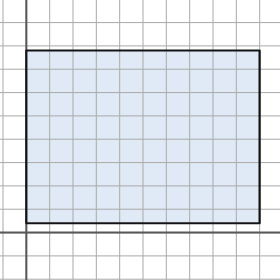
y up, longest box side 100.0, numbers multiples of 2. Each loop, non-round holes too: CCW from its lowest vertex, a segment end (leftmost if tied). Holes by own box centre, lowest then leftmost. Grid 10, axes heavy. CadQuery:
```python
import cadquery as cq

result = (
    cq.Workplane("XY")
    .moveTo(0.0, 4.0)
    .lineTo(100.0, 4.0)
    .lineTo(100.0, 78.0)
    .lineTo(0.0, 78.0)
    .close()
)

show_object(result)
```